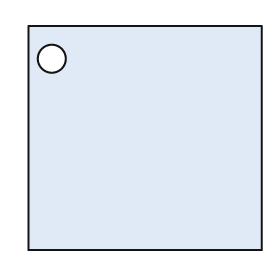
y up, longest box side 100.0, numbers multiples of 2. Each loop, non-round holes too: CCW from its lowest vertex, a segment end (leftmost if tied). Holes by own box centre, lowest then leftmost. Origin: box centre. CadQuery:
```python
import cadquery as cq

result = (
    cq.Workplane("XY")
    .moveTo(-50.0, -48.0)
    .lineTo(50.0, -48.0)
    .lineTo(50.0, 48.0)
    .lineTo(-50.0, 48.0)
    .close()
    .moveTo(-40.0, 34.0)
    .circle(6.0)
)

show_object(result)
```